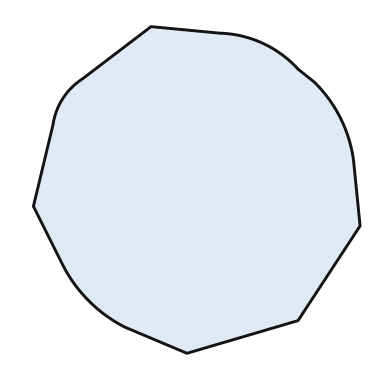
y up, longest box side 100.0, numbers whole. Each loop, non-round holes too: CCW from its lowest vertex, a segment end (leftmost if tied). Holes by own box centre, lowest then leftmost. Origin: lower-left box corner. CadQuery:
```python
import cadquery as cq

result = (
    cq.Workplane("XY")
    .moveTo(47.0, 0.0)
    .lineTo(81.0, 10.0)
    .lineTo(100.0, 39.0)
    .lineTo(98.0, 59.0)
    .threePointArc((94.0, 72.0), (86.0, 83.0))
    .lineTo(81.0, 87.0)
    .threePointArc((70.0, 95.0), (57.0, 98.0))
    .lineTo(36.0, 100.0)
    .lineTo(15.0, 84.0)
    .threePointArc((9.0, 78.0), (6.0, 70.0))
    .lineTo(0.0, 45.0)
    .lineTo(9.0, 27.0)
    .threePointArc((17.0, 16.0), (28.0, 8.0))
    .close()
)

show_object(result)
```